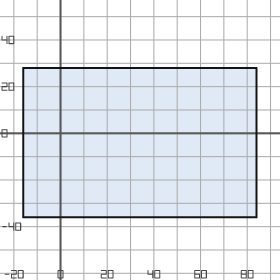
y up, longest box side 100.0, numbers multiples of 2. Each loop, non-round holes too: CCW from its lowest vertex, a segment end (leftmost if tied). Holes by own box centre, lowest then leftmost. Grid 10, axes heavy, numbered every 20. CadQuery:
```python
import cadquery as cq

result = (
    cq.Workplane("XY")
    .moveTo(-16.0, -36.0)
    .lineTo(84.0, -36.0)
    .lineTo(84.0, 28.0)
    .lineTo(-16.0, 28.0)
    .close()
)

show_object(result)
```